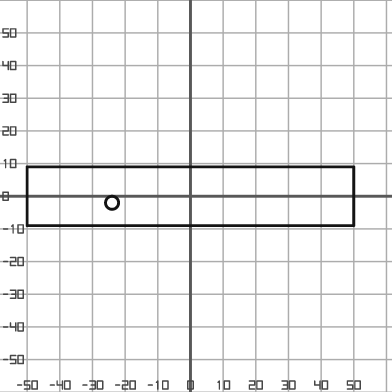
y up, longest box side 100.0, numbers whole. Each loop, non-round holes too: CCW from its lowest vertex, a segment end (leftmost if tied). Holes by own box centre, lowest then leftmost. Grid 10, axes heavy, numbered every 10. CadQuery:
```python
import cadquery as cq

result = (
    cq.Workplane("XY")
    .moveTo(-50.0, -9.0)
    .lineTo(50.0, -9.0)
    .lineTo(50.0, 9.0)
    .lineTo(-50.0, 9.0)
    .close()
    .moveTo(-24.0, -2.0)
    .circle(2.0)
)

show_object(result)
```